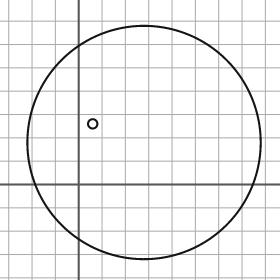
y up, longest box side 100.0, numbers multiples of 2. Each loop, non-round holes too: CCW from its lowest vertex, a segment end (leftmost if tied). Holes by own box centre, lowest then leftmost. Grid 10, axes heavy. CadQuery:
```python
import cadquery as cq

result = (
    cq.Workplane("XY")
    .moveTo(28.0, 18.0)
    .circle(50.0)
    .moveTo(6.0, 26.0)
    .circle(2.0)
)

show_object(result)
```